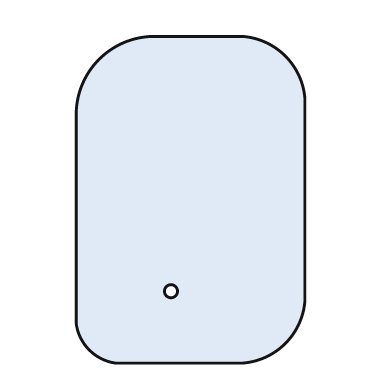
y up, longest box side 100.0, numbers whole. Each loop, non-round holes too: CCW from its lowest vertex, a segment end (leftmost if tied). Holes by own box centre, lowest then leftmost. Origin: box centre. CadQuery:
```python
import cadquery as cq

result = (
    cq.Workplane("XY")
    .moveTo(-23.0, -50.0)
    .lineTo(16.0, -50.0)
    .threePointArc((29.0, -44.0), (35.0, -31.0))
    .lineTo(35.0, 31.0)
    .threePointArc((29.0, 44.0), (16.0, 50.0))
    .lineTo(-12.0, 50.0)
    .threePointArc((-28.0, 43.0), (-35.0, 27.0))
    .lineTo(-35.0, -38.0)
    .threePointArc((-31.0, -46.0), (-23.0, -50.0))
    .close()
    .moveTo(-6.0, -28.0)
    .circle(2.0)
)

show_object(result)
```